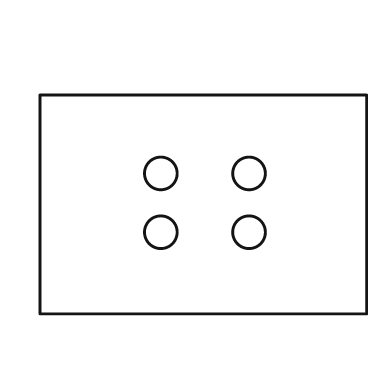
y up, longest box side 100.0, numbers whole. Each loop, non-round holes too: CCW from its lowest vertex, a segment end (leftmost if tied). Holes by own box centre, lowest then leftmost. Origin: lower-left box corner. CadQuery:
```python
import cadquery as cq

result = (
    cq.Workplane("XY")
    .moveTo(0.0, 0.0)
    .lineTo(100.0, 0.0)
    .lineTo(100.0, 67.0)
    .lineTo(0.0, 67.0)
    .close()
    .moveTo(37.0, 25.0)
    .circle(5.0)
    .moveTo(64.0, 25.0)
    .circle(5.0)
    .moveTo(37.0, 43.0)
    .circle(5.0)
    .moveTo(64.0, 43.0)
    .circle(5.0)
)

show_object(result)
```